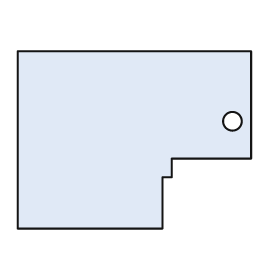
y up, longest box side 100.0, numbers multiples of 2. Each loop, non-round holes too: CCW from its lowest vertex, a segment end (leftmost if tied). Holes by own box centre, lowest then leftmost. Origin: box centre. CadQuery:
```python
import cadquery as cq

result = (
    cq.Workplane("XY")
    .moveTo(-50.0, -38.0)
    .lineTo(12.0, -38.0)
    .lineTo(12.0, -16.0)
    .lineTo(16.0, -16.0)
    .lineTo(16.0, -8.0)
    .lineTo(50.0, -8.0)
    .lineTo(50.0, 38.0)
    .lineTo(-50.0, 38.0)
    .close()
    .moveTo(42.0, 8.0)
    .circle(4.0)
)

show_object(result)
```